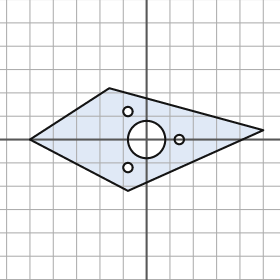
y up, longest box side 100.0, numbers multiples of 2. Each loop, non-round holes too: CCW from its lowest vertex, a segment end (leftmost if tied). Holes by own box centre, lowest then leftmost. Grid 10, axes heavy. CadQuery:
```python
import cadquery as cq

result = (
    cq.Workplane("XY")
    .moveTo(-8.0, -22.0)
    .lineTo(50.0, 4.0)
    .lineTo(-16.0, 22.0)
    .lineTo(-50.0, 0.0)
    .close()
    .moveTo(-8.0, -12.0)
    .circle(2.0)
    .moveTo(0.0, 0.0)
    .circle(8.0)
    .moveTo(14.0, 0.0)
    .circle(2.0)
    .moveTo(-8.0, 12.0)
    .circle(2.0)
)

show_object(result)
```